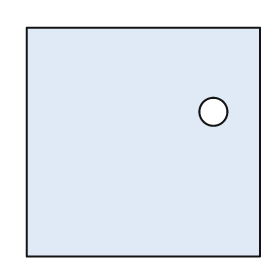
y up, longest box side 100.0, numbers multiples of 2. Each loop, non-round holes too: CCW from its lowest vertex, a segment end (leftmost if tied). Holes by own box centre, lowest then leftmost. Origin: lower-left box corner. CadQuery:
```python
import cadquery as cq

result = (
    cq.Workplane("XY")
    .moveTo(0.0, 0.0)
    .lineTo(100.0, 0.0)
    .lineTo(100.0, 98.0)
    .lineTo(0.0, 98.0)
    .close()
    .moveTo(80.0, 62.0)
    .circle(6.0)
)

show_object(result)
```